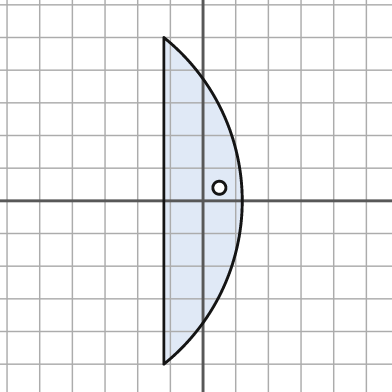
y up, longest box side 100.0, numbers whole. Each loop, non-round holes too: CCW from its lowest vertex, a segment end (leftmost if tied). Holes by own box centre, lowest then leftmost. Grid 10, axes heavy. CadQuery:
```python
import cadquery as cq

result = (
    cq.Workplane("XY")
    .moveTo(-12.0, -50.0)
    .threePointArc((12.0, 0.0), (-12.0, 50.0))
    .close()
    .moveTo(5.0, 4.0)
    .circle(2.0)
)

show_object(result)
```